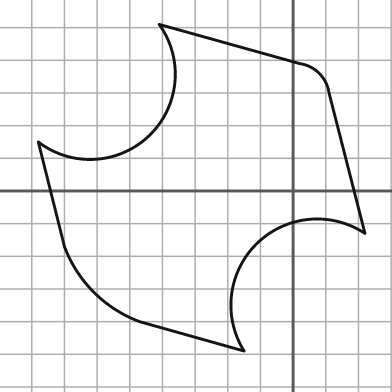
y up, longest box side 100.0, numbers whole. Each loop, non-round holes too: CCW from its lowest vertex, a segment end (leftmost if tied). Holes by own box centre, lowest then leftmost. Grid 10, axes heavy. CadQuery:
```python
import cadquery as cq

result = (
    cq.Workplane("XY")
    .moveTo(-15.0, -49.0)
    .threePointArc((-11.0, -16.0), (22.0, -13.0))
    .lineTo(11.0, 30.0)
    .threePointArc((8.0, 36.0), (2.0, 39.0))
    .lineTo(-41.0, 51.0)
    .threePointArc((-44.0, 17.0), (-78.0, 15.0))
    .lineTo(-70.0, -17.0)
    .threePointArc((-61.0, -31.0), (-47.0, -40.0))
    .close()
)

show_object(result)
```